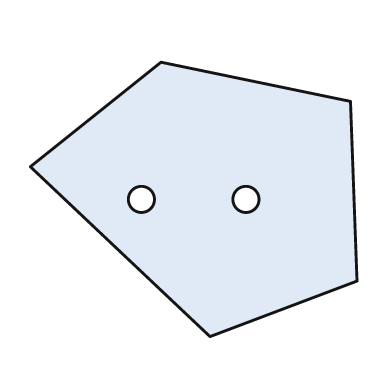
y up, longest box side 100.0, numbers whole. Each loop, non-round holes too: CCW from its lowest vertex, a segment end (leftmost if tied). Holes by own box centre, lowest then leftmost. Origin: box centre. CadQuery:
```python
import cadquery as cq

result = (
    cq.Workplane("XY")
    .moveTo(5.0, -42.0)
    .lineTo(50.0, -25.0)
    .lineTo(48.0, 30.0)
    .lineTo(-10.0, 42.0)
    .lineTo(-50.0, 10.0)
    .close()
    .moveTo(-16.0, 0.0)
    .circle(4.0)
    .moveTo(16.0, 0.0)
    .circle(4.0)
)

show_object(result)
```